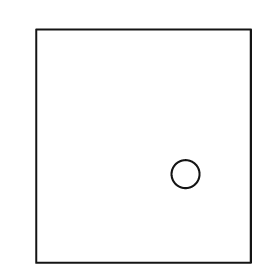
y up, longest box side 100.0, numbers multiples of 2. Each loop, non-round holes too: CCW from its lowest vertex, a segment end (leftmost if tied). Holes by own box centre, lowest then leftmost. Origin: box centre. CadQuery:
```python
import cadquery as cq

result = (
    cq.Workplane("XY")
    .moveTo(-46.0, -50.0)
    .lineTo(46.0, -50.0)
    .lineTo(46.0, 50.0)
    .lineTo(-46.0, 50.0)
    .close()
    .moveTo(18.0, -12.0)
    .circle(6.0)
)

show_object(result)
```